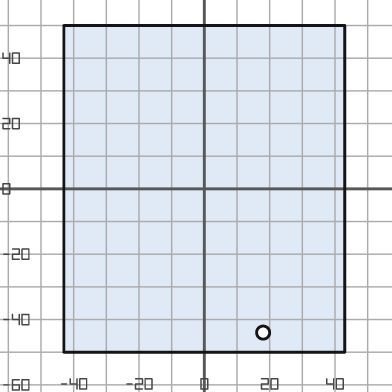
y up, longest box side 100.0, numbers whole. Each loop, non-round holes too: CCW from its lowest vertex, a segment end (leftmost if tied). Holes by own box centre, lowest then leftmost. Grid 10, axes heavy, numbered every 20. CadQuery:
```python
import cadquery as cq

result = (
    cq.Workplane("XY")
    .moveTo(-43.0, -50.0)
    .lineTo(43.0, -50.0)
    .lineTo(43.0, 50.0)
    .lineTo(-43.0, 50.0)
    .close()
    .moveTo(18.0, -44.0)
    .circle(2.0)
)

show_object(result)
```